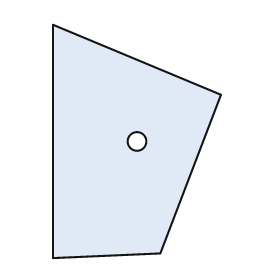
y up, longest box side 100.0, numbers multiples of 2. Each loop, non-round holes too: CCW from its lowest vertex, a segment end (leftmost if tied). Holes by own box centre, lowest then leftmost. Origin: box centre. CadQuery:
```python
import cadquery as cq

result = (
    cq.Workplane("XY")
    .moveTo(-36.0, -50.0)
    .lineTo(10.0, -48.0)
    .lineTo(36.0, 20.0)
    .lineTo(-36.0, 50.0)
    .close()
    .moveTo(0.0, 0.0)
    .circle(4.0)
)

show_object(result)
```